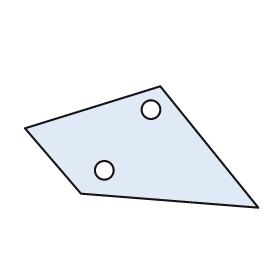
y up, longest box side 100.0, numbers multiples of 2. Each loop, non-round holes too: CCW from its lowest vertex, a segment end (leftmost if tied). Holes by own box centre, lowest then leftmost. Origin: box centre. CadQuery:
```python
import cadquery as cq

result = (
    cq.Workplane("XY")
    .moveTo(50.0, -26.0)
    .lineTo(8.0, 26.0)
    .lineTo(-50.0, 8.0)
    .lineTo(-26.0, -20.0)
    .close()
    .moveTo(-16.0, -10.0)
    .circle(4.0)
    .moveTo(4.0, 16.0)
    .circle(4.0)
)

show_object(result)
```